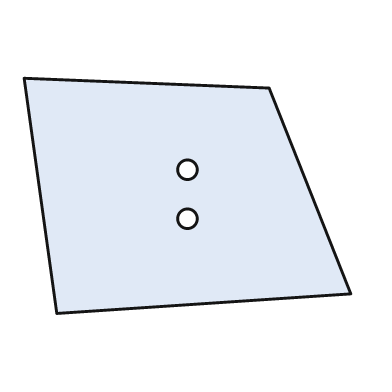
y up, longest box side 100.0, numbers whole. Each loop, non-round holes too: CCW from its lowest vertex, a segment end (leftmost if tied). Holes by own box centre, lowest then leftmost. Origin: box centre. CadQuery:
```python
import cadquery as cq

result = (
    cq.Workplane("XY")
    .moveTo(-40.0, -36.0)
    .lineTo(50.0, -30.0)
    .lineTo(25.0, 33.0)
    .lineTo(-50.0, 36.0)
    .close()
    .moveTo(0.0, -7.0)
    .circle(3.0)
    .moveTo(0.0, 8.0)
    .circle(3.0)
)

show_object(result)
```